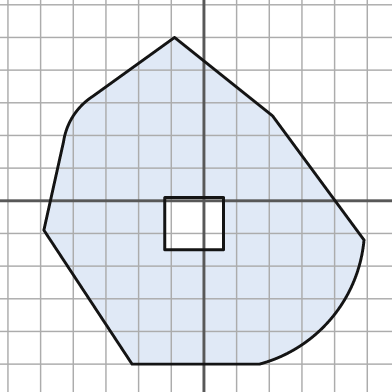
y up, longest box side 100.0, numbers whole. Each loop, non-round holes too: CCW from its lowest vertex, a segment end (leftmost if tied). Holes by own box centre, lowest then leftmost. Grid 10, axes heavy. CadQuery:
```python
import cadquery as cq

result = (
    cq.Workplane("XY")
    .moveTo(-22.0, -50.0)
    .lineTo(17.0, -50.0)
    .threePointArc((39.0, -36.0), (49.0, -12.0))
    .lineTo(21.0, 26.0)
    .lineTo(-9.0, 50.0)
    .lineTo(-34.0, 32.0)
    .threePointArc((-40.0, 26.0), (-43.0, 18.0))
    .lineTo(-49.0, -9.0)
    .close()
    .moveTo(-12.0, -15.0)
    .lineTo(6.0, -15.0)
    .lineTo(6.0, 1.0)
    .lineTo(-12.0, 1.0)
    .close()
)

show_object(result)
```